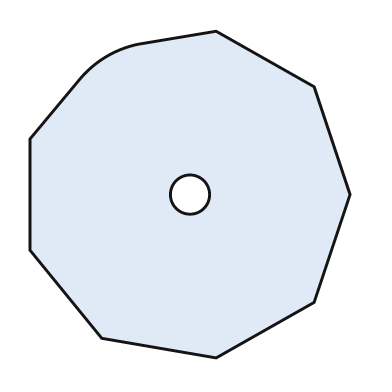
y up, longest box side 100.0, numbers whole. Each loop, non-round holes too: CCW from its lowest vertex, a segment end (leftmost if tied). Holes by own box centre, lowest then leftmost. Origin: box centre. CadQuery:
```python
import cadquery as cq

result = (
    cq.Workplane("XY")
    .moveTo(8.0, -50.0)
    .lineTo(38.0, -33.0)
    .lineTo(49.0, 0.0)
    .lineTo(38.0, 33.0)
    .lineTo(8.0, 50.0)
    .lineTo(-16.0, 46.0)
    .threePointArc((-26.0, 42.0), (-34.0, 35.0))
    .lineTo(-49.0, 17.0)
    .lineTo(-49.0, -17.0)
    .lineTo(-27.0, -44.0)
    .close()
    .moveTo(0.0, 0.0)
    .circle(6.0)
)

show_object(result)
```